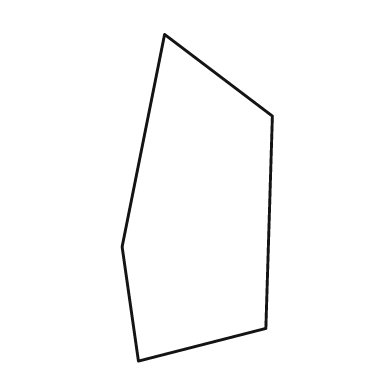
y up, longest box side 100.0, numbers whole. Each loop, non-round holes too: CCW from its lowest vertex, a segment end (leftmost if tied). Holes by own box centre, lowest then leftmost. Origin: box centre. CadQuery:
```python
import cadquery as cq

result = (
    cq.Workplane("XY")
    .moveTo(-18.0, -50.0)
    .lineTo(21.0, -40.0)
    .lineTo(23.0, 25.0)
    .lineTo(-10.0, 50.0)
    .lineTo(-23.0, -15.0)
    .close()
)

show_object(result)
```